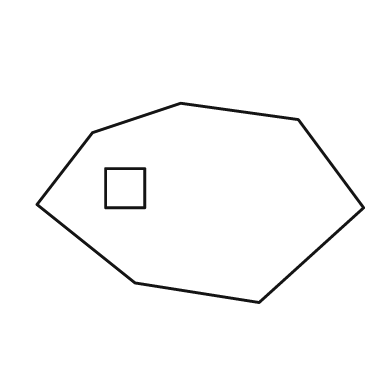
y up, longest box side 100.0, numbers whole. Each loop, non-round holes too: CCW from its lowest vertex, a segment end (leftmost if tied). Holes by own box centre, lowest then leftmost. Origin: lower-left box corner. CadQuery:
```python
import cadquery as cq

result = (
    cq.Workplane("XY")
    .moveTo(68.0, 0.0)
    .lineTo(100.0, 29.0)
    .lineTo(80.0, 56.0)
    .lineTo(44.0, 61.0)
    .lineTo(17.0, 52.0)
    .lineTo(0.0, 30.0)
    .lineTo(30.0, 6.0)
    .close()
    .moveTo(21.0, 29.0)
    .lineTo(33.0, 29.0)
    .lineTo(33.0, 41.0)
    .lineTo(21.0, 41.0)
    .close()
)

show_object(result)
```